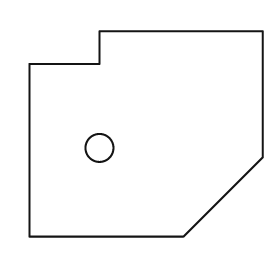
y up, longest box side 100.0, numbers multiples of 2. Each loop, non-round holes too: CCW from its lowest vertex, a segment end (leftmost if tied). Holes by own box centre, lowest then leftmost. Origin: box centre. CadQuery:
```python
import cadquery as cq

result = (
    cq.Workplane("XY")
    .moveTo(-50.0, -44.0)
    .lineTo(16.0, -44.0)
    .lineTo(50.0, -10.0)
    .lineTo(50.0, 44.0)
    .lineTo(-20.0, 44.0)
    .lineTo(-20.0, 30.0)
    .lineTo(-50.0, 30.0)
    .close()
    .moveTo(-20.0, -6.0)
    .circle(6.0)
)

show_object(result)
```